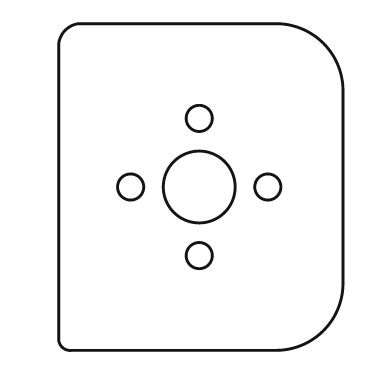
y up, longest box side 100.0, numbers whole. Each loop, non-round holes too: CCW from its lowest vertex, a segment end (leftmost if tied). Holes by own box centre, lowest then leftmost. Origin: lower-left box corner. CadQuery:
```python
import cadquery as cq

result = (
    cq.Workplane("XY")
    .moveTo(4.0, 0.0)
    .lineTo(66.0, 0.0)
    .threePointArc((81.0, 6.0), (87.0, 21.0))
    .lineTo(87.0, 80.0)
    .threePointArc((81.0, 94.0), (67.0, 100.0))
    .lineTo(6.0, 100.0)
    .threePointArc((2.0, 98.0), (0.0, 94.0))
    .lineTo(0.0, 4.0)
    .threePointArc((1.0, 1.0), (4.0, 0.0))
    .close()
    .moveTo(43.0, 29.0)
    .circle(4.0)
    .moveTo(22.0, 50.0)
    .circle(4.0)
    .moveTo(43.0, 50.0)
    .circle(11.0)
    .moveTo(64.0, 50.0)
    .circle(4.0)
    .moveTo(43.0, 71.0)
    .circle(4.0)
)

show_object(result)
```